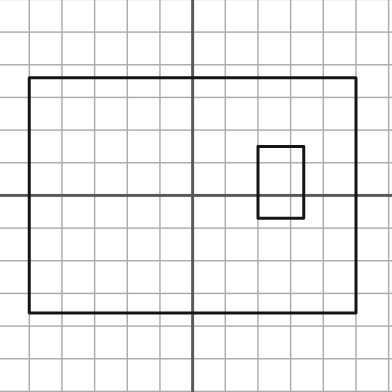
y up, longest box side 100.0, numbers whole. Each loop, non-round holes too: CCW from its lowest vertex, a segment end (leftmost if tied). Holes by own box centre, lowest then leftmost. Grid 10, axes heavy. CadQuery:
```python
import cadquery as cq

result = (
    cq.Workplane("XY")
    .moveTo(-50.0, -36.0)
    .lineTo(50.0, -36.0)
    .lineTo(50.0, 36.0)
    .lineTo(-50.0, 36.0)
    .close()
    .moveTo(20.0, -7.0)
    .lineTo(34.0, -7.0)
    .lineTo(34.0, 15.0)
    .lineTo(20.0, 15.0)
    .close()
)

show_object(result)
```